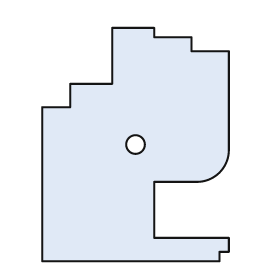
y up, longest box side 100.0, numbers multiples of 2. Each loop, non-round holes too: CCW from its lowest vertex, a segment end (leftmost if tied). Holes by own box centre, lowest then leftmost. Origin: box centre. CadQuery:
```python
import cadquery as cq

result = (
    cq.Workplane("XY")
    .moveTo(-40.0, -50.0)
    .lineTo(36.0, -50.0)
    .lineTo(36.0, -46.0)
    .lineTo(40.0, -46.0)
    .lineTo(40.0, -40.0)
    .lineTo(8.0, -40.0)
    .lineTo(8.0, -16.0)
    .lineTo(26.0, -16.0)
    .threePointArc((36.0, -12.0), (40.0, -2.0))
    .lineTo(40.0, 40.0)
    .lineTo(24.0, 40.0)
    .lineTo(24.0, 46.0)
    .lineTo(8.0, 46.0)
    .lineTo(8.0, 50.0)
    .lineTo(-10.0, 50.0)
    .lineTo(-10.0, 26.0)
    .lineTo(-28.0, 26.0)
    .lineTo(-28.0, 16.0)
    .lineTo(-40.0, 16.0)
    .close()
    .moveTo(0.0, 0.0)
    .circle(4.0)
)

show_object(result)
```